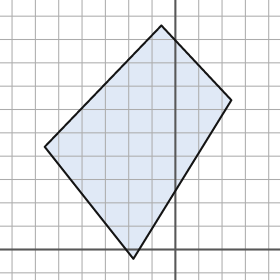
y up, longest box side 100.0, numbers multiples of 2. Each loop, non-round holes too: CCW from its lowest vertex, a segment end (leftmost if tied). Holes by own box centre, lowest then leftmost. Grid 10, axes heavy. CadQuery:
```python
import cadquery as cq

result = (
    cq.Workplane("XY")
    .moveTo(-18.0, -4.0)
    .lineTo(24.0, 64.0)
    .lineTo(-6.0, 96.0)
    .lineTo(-56.0, 44.0)
    .close()
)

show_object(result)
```